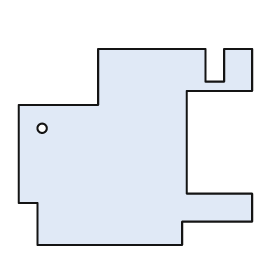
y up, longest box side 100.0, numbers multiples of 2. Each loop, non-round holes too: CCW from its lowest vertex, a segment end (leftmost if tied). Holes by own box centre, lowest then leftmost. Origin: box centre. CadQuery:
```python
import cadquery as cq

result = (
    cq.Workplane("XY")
    .moveTo(-42.0, -42.0)
    .lineTo(20.0, -42.0)
    .lineTo(20.0, -32.0)
    .lineTo(50.0, -32.0)
    .lineTo(50.0, -20.0)
    .lineTo(22.0, -20.0)
    .lineTo(22.0, 24.0)
    .lineTo(50.0, 24.0)
    .lineTo(50.0, 42.0)
    .lineTo(38.0, 42.0)
    .lineTo(38.0, 28.0)
    .lineTo(30.0, 28.0)
    .lineTo(30.0, 42.0)
    .lineTo(-16.0, 42.0)
    .lineTo(-16.0, 18.0)
    .lineTo(-50.0, 18.0)
    .lineTo(-50.0, -24.0)
    .lineTo(-42.0, -24.0)
    .close()
    .moveTo(-40.0, 8.0)
    .circle(2.0)
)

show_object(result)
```